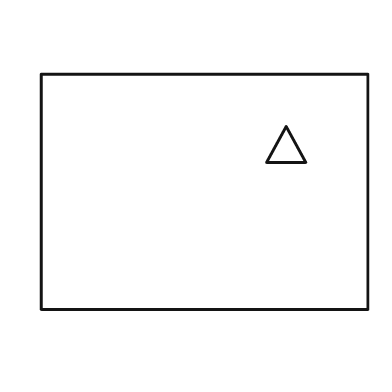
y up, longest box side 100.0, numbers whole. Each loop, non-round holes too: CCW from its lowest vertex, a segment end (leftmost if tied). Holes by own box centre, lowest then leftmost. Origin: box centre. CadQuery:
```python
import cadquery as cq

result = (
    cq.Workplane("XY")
    .moveTo(-50.0, -36.0)
    .lineTo(50.0, -36.0)
    .lineTo(50.0, 36.0)
    .lineTo(-50.0, 36.0)
    .close()
    .moveTo(19.0, 9.0)
    .lineTo(31.0, 9.0)
    .lineTo(25.0, 20.0)
    .close()
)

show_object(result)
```